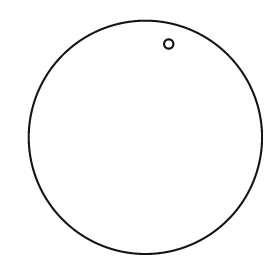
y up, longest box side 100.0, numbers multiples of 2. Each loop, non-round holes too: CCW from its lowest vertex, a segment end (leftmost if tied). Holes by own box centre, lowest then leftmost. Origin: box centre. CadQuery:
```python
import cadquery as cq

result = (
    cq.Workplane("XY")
    .moveTo(0.0, 0.0)
    .circle(50.0)
    .moveTo(10.0, 40.0)
    .circle(2.0)
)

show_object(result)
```